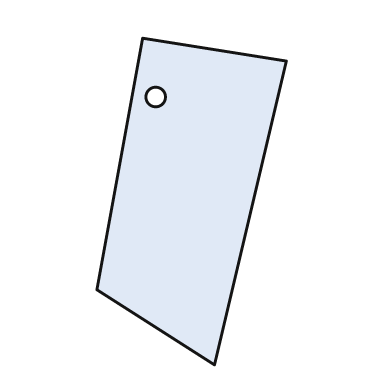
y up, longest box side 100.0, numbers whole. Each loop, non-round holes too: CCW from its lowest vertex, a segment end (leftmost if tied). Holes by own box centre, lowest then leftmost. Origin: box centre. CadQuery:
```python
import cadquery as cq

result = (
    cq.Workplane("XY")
    .moveTo(7.0, -50.0)
    .lineTo(29.0, 43.0)
    .lineTo(-15.0, 50.0)
    .lineTo(-29.0, -27.0)
    .close()
    .moveTo(-11.0, 32.0)
    .circle(3.0)
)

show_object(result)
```